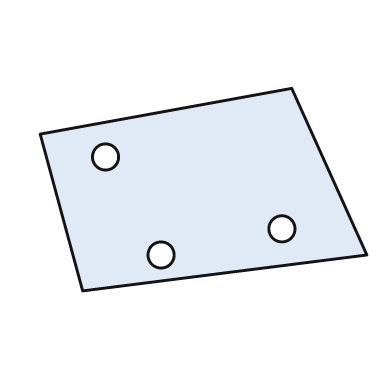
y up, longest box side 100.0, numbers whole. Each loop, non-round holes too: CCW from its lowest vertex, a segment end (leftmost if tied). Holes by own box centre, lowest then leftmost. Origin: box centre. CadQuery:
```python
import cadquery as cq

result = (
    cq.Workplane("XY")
    .moveTo(-37.0, -31.0)
    .lineTo(50.0, -20.0)
    .lineTo(27.0, 31.0)
    .lineTo(-50.0, 17.0)
    .close()
    .moveTo(-13.0, -20.0)
    .circle(4.0)
    .moveTo(24.0, -12.0)
    .circle(4.0)
    .moveTo(-30.0, 10.0)
    .circle(4.0)
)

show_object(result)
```